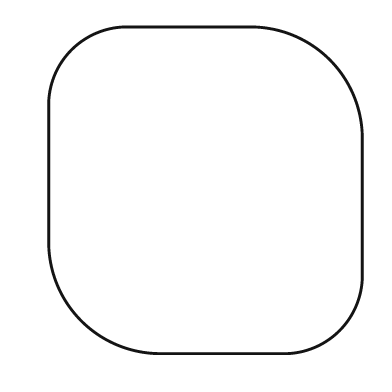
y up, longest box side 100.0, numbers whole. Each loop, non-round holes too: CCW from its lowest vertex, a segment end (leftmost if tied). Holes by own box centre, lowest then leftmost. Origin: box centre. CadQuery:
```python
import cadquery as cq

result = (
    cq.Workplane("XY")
    .moveTo(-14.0, -50.0)
    .lineTo(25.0, -50.0)
    .threePointArc((41.0, -43.0), (48.0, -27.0))
    .lineTo(48.0, 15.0)
    .threePointArc((38.0, 40.0), (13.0, 50.0))
    .lineTo(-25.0, 50.0)
    .threePointArc((-41.0, 43.0), (-48.0, 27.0))
    .lineTo(-48.0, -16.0)
    .threePointArc((-38.0, -40.0), (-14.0, -50.0))
    .close()
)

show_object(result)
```